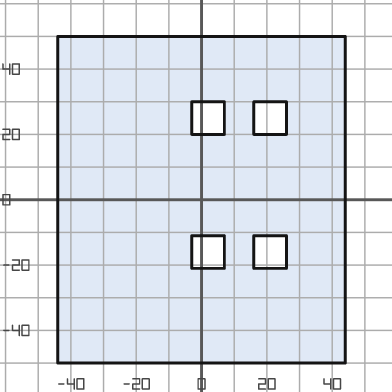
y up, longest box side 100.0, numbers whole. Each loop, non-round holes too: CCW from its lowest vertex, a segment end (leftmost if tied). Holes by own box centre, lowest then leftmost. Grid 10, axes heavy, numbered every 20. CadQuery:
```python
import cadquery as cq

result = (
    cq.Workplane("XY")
    .moveTo(-44.0, -50.0)
    .lineTo(44.0, -50.0)
    .lineTo(44.0, 50.0)
    .lineTo(-44.0, 50.0)
    .close()
    .moveTo(-3.0, -21.0)
    .lineTo(7.0, -21.0)
    .lineTo(7.0, -11.0)
    .lineTo(-3.0, -11.0)
    .close()
    .moveTo(16.0, -21.0)
    .lineTo(26.0, -21.0)
    .lineTo(26.0, -11.0)
    .lineTo(16.0, -11.0)
    .close()
    .moveTo(-3.0, 20.0)
    .lineTo(7.0, 20.0)
    .lineTo(7.0, 30.0)
    .lineTo(-3.0, 30.0)
    .close()
    .moveTo(16.0, 20.0)
    .lineTo(26.0, 20.0)
    .lineTo(26.0, 30.0)
    .lineTo(16.0, 30.0)
    .close()
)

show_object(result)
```